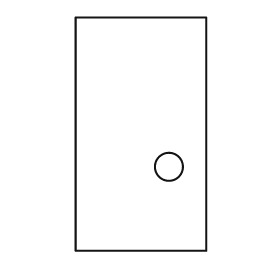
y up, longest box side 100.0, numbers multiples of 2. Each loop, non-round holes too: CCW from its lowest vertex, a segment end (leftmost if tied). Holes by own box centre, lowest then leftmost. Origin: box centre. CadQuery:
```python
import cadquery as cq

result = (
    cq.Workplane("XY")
    .moveTo(-28.0, -50.0)
    .lineTo(28.0, -50.0)
    .lineTo(28.0, 50.0)
    .lineTo(-28.0, 50.0)
    .close()
    .moveTo(12.0, -14.0)
    .circle(6.0)
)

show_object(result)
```